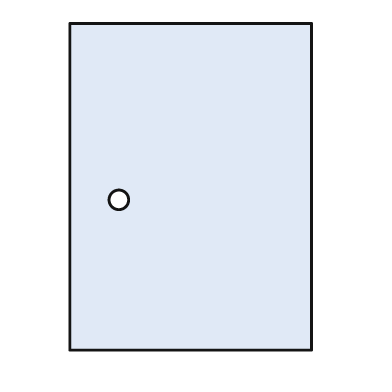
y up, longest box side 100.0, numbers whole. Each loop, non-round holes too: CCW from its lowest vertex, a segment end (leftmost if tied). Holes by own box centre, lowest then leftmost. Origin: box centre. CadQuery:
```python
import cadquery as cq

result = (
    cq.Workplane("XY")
    .moveTo(-37.0, -50.0)
    .lineTo(37.0, -50.0)
    .lineTo(37.0, 50.0)
    .lineTo(-37.0, 50.0)
    .close()
    .moveTo(-22.0, -4.0)
    .circle(3.0)
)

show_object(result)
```